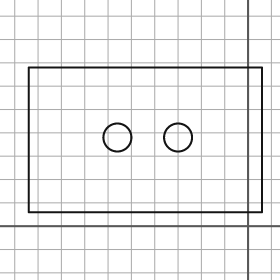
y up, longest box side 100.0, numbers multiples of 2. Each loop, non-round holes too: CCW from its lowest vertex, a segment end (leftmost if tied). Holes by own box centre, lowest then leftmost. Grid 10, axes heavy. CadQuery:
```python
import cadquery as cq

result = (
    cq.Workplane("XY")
    .moveTo(-94.0, 6.0)
    .lineTo(6.0, 6.0)
    .lineTo(6.0, 68.0)
    .lineTo(-94.0, 68.0)
    .close()
    .moveTo(-56.0, 38.0)
    .circle(6.0)
    .moveTo(-30.0, 38.0)
    .circle(6.0)
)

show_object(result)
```